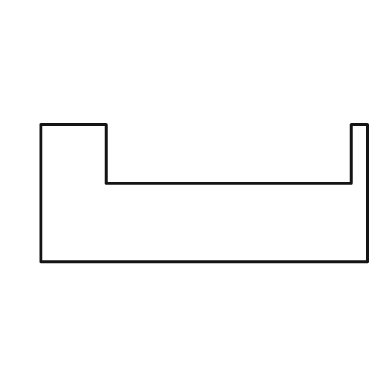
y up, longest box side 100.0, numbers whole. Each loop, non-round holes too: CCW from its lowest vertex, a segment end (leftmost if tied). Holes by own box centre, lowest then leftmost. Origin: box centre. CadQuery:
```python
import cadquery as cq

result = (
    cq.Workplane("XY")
    .moveTo(-50.0, -21.0)
    .lineTo(50.0, -21.0)
    .lineTo(50.0, 21.0)
    .lineTo(45.0, 21.0)
    .lineTo(45.0, 3.0)
    .lineTo(-30.0, 3.0)
    .lineTo(-30.0, 21.0)
    .lineTo(-50.0, 21.0)
    .close()
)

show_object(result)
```